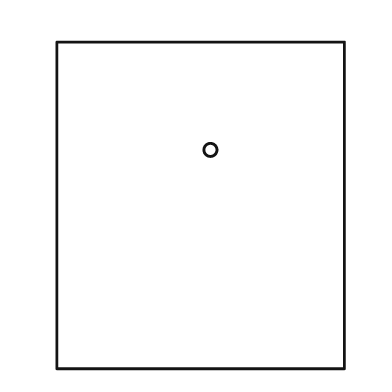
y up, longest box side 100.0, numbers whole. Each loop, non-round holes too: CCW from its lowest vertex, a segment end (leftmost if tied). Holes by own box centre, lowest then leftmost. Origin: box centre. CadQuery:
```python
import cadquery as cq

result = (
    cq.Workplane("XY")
    .moveTo(-44.0, -50.0)
    .lineTo(44.0, -50.0)
    .lineTo(44.0, 50.0)
    .lineTo(-44.0, 50.0)
    .close()
    .moveTo(3.0, 17.0)
    .circle(2.0)
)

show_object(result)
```